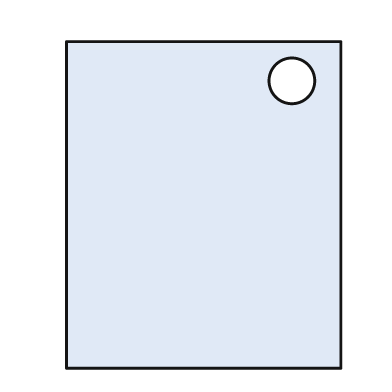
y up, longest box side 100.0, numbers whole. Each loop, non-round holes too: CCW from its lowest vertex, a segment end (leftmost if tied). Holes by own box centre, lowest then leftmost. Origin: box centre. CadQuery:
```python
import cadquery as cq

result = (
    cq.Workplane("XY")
    .moveTo(-42.0, -50.0)
    .lineTo(42.0, -50.0)
    .lineTo(42.0, 50.0)
    .lineTo(-42.0, 50.0)
    .close()
    .moveTo(27.0, 38.0)
    .circle(7.0)
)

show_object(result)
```